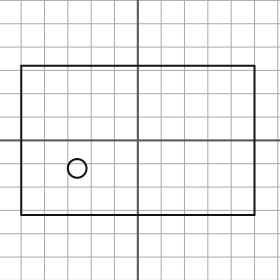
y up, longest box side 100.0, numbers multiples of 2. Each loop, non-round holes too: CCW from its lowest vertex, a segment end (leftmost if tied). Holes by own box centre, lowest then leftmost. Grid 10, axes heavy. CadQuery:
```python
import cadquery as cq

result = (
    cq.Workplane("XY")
    .moveTo(-50.0, -32.0)
    .lineTo(50.0, -32.0)
    .lineTo(50.0, 32.0)
    .lineTo(-50.0, 32.0)
    .close()
    .moveTo(-26.0, -12.0)
    .circle(4.0)
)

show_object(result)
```